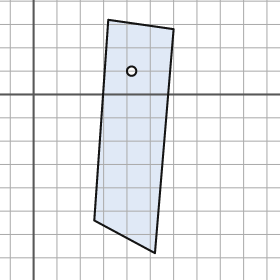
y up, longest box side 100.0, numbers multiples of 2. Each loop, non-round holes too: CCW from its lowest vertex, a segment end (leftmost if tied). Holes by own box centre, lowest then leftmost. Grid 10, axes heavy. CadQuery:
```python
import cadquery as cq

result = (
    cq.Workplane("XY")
    .moveTo(52.0, -68.0)
    .lineTo(60.0, 28.0)
    .lineTo(32.0, 32.0)
    .lineTo(26.0, -54.0)
    .close()
    .moveTo(42.0, 10.0)
    .circle(2.0)
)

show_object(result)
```